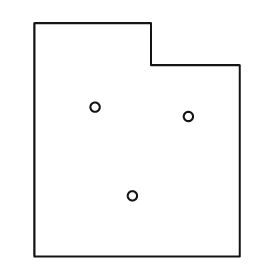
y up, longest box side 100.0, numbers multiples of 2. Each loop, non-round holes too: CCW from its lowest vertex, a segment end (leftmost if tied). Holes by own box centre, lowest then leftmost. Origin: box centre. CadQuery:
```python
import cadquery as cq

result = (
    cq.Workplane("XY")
    .moveTo(-44.0, -50.0)
    .lineTo(44.0, -50.0)
    .lineTo(44.0, 32.0)
    .lineTo(6.0, 32.0)
    .lineTo(6.0, 50.0)
    .lineTo(-44.0, 50.0)
    .close()
    .moveTo(-2.0, -24.0)
    .circle(2.0)
    .moveTo(22.0, 10.0)
    .circle(2.0)
    .moveTo(-18.0, 14.0)
    .circle(2.0)
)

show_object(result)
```